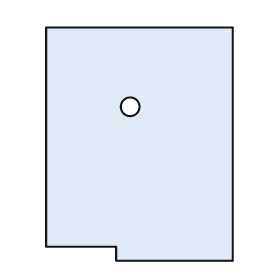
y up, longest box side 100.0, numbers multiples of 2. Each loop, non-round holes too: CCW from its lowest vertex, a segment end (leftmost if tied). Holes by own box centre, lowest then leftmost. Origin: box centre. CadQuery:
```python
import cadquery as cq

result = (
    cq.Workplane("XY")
    .moveTo(-10.0, -50.0)
    .lineTo(40.0, -50.0)
    .lineTo(40.0, 50.0)
    .lineTo(-40.0, 50.0)
    .lineTo(-40.0, -44.0)
    .lineTo(-10.0, -44.0)
    .close()
    .moveTo(-4.0, 16.0)
    .circle(4.0)
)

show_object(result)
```